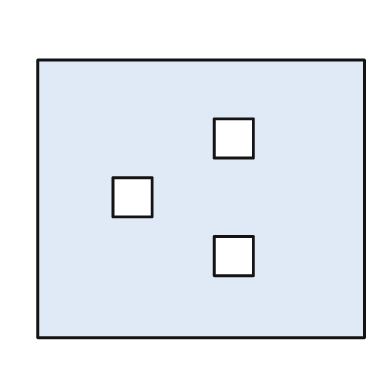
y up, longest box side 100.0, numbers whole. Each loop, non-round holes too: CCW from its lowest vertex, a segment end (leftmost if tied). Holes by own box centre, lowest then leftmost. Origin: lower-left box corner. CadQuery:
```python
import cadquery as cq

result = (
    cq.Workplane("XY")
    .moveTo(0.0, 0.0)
    .lineTo(100.0, 0.0)
    .lineTo(100.0, 85.0)
    .lineTo(0.0, 85.0)
    .close()
    .moveTo(54.0, 19.0)
    .lineTo(66.0, 19.0)
    .lineTo(66.0, 31.0)
    .lineTo(54.0, 31.0)
    .close()
    .moveTo(23.0, 37.0)
    .lineTo(35.0, 37.0)
    .lineTo(35.0, 49.0)
    .lineTo(23.0, 49.0)
    .close()
    .moveTo(54.0, 55.0)
    .lineTo(66.0, 55.0)
    .lineTo(66.0, 67.0)
    .lineTo(54.0, 67.0)
    .close()
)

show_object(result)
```